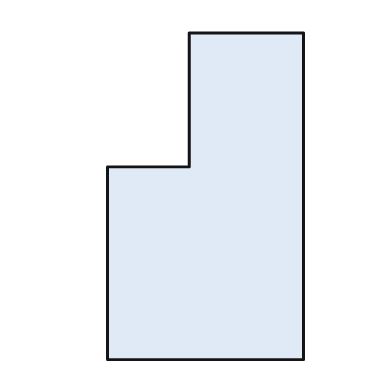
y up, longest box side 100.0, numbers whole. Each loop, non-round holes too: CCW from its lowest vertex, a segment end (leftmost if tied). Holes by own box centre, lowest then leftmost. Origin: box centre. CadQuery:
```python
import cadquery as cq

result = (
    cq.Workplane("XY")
    .moveTo(-30.0, -50.0)
    .lineTo(30.0, -50.0)
    .lineTo(30.0, 50.0)
    .lineTo(-5.0, 50.0)
    .lineTo(-5.0, 9.0)
    .lineTo(-30.0, 9.0)
    .close()
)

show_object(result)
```